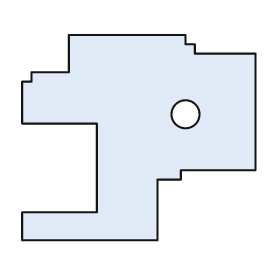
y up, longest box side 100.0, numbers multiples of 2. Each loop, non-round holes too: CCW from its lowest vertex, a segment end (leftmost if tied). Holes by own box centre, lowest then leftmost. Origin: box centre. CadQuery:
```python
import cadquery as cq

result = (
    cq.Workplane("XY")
    .moveTo(-50.0, -44.0)
    .lineTo(8.0, -44.0)
    .lineTo(8.0, -18.0)
    .lineTo(18.0, -18.0)
    .lineTo(18.0, -14.0)
    .lineTo(50.0, -14.0)
    .lineTo(50.0, 36.0)
    .lineTo(24.0, 36.0)
    .lineTo(24.0, 40.0)
    .lineTo(20.0, 40.0)
    .lineTo(20.0, 44.0)
    .lineTo(-30.0, 44.0)
    .lineTo(-30.0, 28.0)
    .lineTo(-46.0, 28.0)
    .lineTo(-46.0, 24.0)
    .lineTo(-50.0, 24.0)
    .lineTo(-50.0, 6.0)
    .lineTo(-18.0, 6.0)
    .lineTo(-18.0, -32.0)
    .lineTo(-50.0, -32.0)
    .close()
    .moveTo(20.0, 10.0)
    .circle(6.0)
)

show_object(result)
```